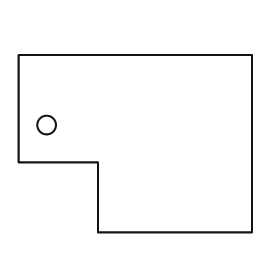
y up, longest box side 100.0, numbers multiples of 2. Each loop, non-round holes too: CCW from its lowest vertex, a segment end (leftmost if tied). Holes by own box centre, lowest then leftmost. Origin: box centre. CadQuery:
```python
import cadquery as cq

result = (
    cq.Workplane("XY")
    .moveTo(-16.0, -38.0)
    .lineTo(50.0, -38.0)
    .lineTo(50.0, 38.0)
    .lineTo(-50.0, 38.0)
    .lineTo(-50.0, -8.0)
    .lineTo(-16.0, -8.0)
    .close()
    .moveTo(-38.0, 8.0)
    .circle(4.0)
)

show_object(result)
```